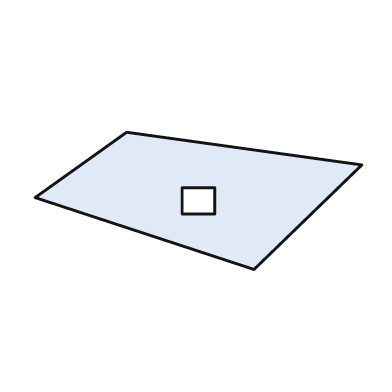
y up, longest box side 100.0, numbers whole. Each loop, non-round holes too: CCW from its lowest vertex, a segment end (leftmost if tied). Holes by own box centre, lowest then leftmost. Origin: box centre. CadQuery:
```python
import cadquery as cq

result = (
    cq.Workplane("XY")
    .moveTo(17.0, -21.0)
    .lineTo(50.0, 11.0)
    .lineTo(-22.0, 21.0)
    .lineTo(-50.0, 1.0)
    .close()
    .moveTo(-5.0, -4.0)
    .lineTo(5.0, -4.0)
    .lineTo(5.0, 4.0)
    .lineTo(-5.0, 4.0)
    .close()
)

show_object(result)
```